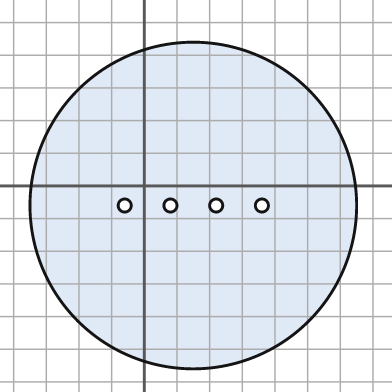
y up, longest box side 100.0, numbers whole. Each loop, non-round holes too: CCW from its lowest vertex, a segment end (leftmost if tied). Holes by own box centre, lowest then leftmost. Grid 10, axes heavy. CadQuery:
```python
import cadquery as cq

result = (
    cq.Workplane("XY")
    .moveTo(15.0, -6.0)
    .circle(50.0)
    .moveTo(-6.0, -6.0)
    .circle(2.0)
    .moveTo(8.0, -6.0)
    .circle(2.0)
    .moveTo(22.0, -6.0)
    .circle(2.0)
    .moveTo(36.0, -6.0)
    .circle(2.0)
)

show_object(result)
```